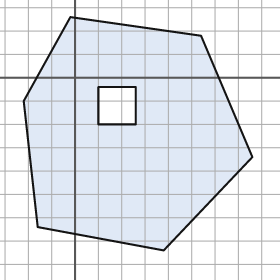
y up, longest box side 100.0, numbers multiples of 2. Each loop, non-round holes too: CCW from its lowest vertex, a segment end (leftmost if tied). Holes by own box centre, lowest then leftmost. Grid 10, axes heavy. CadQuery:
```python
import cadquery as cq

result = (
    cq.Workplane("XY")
    .moveTo(38.0, -74.0)
    .lineTo(76.0, -34.0)
    .lineTo(54.0, 18.0)
    .lineTo(-2.0, 26.0)
    .lineTo(-22.0, -10.0)
    .lineTo(-16.0, -64.0)
    .close()
    .moveTo(10.0, -20.0)
    .lineTo(26.0, -20.0)
    .lineTo(26.0, -4.0)
    .lineTo(10.0, -4.0)
    .close()
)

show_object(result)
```